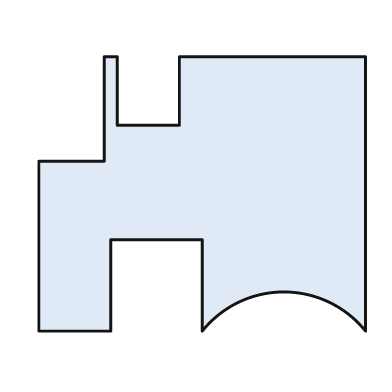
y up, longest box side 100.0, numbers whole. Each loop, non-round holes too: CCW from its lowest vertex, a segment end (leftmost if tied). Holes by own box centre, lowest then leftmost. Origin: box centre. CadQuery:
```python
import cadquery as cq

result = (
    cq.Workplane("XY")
    .moveTo(-50.0, -42.0)
    .lineTo(-28.0, -42.0)
    .lineTo(-28.0, -14.0)
    .lineTo(0.0, -14.0)
    .lineTo(0.0, -42.0)
    .threePointArc((25.0, -30.0), (50.0, -42.0))
    .lineTo(50.0, 42.0)
    .lineTo(-7.0, 42.0)
    .lineTo(-7.0, 21.0)
    .lineTo(-26.0, 21.0)
    .lineTo(-26.0, 42.0)
    .lineTo(-30.0, 42.0)
    .lineTo(-30.0, 10.0)
    .lineTo(-50.0, 10.0)
    .close()
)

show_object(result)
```